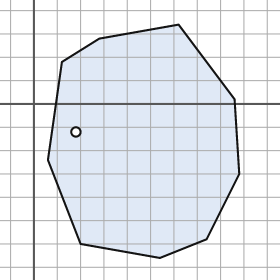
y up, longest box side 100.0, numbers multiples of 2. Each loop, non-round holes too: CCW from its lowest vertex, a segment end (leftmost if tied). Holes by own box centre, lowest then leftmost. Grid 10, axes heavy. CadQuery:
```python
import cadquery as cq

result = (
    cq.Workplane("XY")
    .moveTo(54.0, -66.0)
    .lineTo(74.0, -58.0)
    .lineTo(88.0, -30.0)
    .lineTo(86.0, 2.0)
    .lineTo(62.0, 34.0)
    .lineTo(28.0, 28.0)
    .lineTo(12.0, 18.0)
    .lineTo(6.0, -24.0)
    .lineTo(20.0, -60.0)
    .close()
    .moveTo(18.0, -12.0)
    .circle(2.0)
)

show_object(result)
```